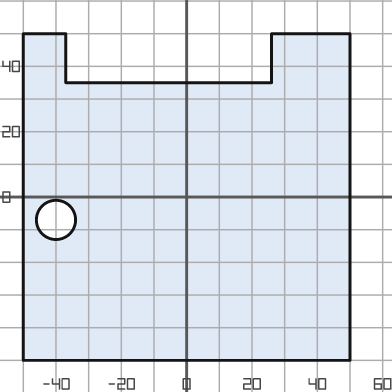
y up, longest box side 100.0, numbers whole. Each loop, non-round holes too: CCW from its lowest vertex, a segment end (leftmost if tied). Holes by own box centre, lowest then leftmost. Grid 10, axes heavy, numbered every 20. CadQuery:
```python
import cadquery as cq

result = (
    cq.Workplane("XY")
    .moveTo(-50.0, -50.0)
    .lineTo(50.0, -50.0)
    .lineTo(50.0, 50.0)
    .lineTo(26.0, 50.0)
    .lineTo(26.0, 35.0)
    .lineTo(-37.0, 35.0)
    .lineTo(-37.0, 50.0)
    .lineTo(-50.0, 50.0)
    .close()
    .moveTo(-40.0, -7.0)
    .circle(6.0)
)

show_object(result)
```